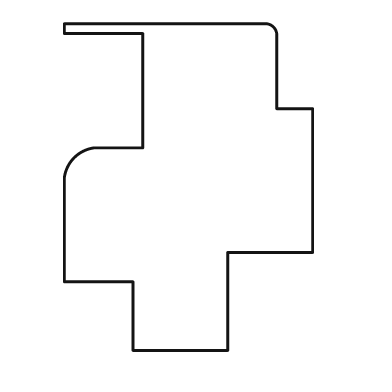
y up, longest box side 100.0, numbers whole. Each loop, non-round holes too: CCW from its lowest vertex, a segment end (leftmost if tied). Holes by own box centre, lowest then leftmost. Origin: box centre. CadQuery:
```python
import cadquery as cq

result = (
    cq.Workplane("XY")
    .moveTo(-17.0, -50.0)
    .lineTo(12.0, -50.0)
    .lineTo(12.0, -20.0)
    .lineTo(38.0, -20.0)
    .lineTo(38.0, 24.0)
    .lineTo(27.0, 24.0)
    .lineTo(27.0, 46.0)
    .threePointArc((26.0, 49.0), (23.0, 50.0))
    .lineTo(-38.0, 50.0)
    .lineTo(-38.0, 47.0)
    .lineTo(-14.0, 47.0)
    .lineTo(-14.0, 12.0)
    .lineTo(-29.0, 12.0)
    .threePointArc((-35.0, 9.0), (-38.0, 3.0))
    .lineTo(-38.0, -29.0)
    .lineTo(-17.0, -29.0)
    .close()
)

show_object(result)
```